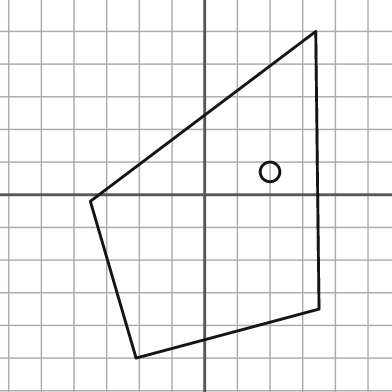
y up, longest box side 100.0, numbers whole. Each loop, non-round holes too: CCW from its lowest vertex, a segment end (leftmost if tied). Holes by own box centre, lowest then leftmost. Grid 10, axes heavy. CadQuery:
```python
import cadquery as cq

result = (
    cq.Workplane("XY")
    .moveTo(-21.0, -50.0)
    .lineTo(35.0, -35.0)
    .lineTo(34.0, 50.0)
    .lineTo(-35.0, -2.0)
    .close()
    .moveTo(20.0, 7.0)
    .circle(3.0)
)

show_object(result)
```